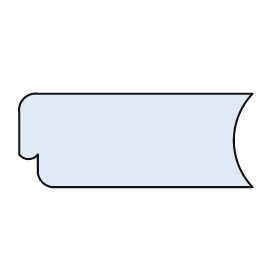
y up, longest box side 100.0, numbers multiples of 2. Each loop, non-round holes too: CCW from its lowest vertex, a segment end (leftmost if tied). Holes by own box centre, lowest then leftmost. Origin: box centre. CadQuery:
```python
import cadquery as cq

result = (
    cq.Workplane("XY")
    .moveTo(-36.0, -20.0)
    .lineTo(50.0, -20.0)
    .threePointArc((42.0, 0.0), (50.0, 20.0))
    .lineTo(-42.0, 20.0)
    .threePointArc((-48.0, 18.0), (-50.0, 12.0))
    .lineTo(-50.0, -6.0)
    .threePointArc((-46.0, -8.0), (-42.0, -6.0))
    .lineTo(-42.0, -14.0)
    .threePointArc((-40.0, -18.0), (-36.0, -20.0))
    .close()
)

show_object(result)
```